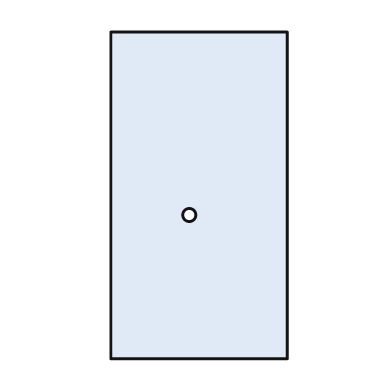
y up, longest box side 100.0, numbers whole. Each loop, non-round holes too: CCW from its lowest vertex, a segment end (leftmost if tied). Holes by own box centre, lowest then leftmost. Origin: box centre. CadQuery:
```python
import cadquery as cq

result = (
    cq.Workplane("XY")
    .moveTo(-27.0, -50.0)
    .lineTo(27.0, -50.0)
    .lineTo(27.0, 50.0)
    .lineTo(-27.0, 50.0)
    .close()
    .moveTo(-3.0, -6.0)
    .circle(2.0)
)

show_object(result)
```